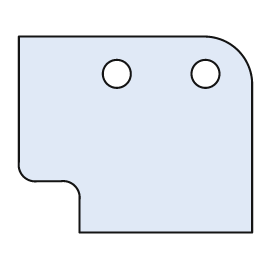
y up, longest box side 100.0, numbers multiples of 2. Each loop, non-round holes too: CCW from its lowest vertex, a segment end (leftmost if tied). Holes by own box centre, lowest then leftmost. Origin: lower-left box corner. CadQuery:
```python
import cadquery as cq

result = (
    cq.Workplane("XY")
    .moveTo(26.0, 0.0)
    .lineTo(100.0, 0.0)
    .lineTo(100.0, 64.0)
    .threePointArc((94.0, 78.0), (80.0, 84.0))
    .lineTo(0.0, 84.0)
    .lineTo(0.0, 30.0)
    .threePointArc((2.0, 24.0), (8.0, 22.0))
    .lineTo(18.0, 22.0)
    .threePointArc((24.0, 20.0), (26.0, 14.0))
    .close()
    .moveTo(42.0, 68.0)
    .circle(6.0)
    .moveTo(80.0, 68.0)
    .circle(6.0)
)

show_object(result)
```